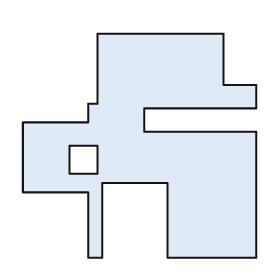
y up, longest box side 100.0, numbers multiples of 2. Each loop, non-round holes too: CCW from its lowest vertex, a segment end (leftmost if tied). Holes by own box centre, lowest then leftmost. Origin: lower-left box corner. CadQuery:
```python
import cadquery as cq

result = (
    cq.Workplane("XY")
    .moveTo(28.0, 0.0)
    .lineTo(34.0, 0.0)
    .lineTo(34.0, 32.0)
    .lineTo(62.0, 32.0)
    .lineTo(62.0, 0.0)
    .lineTo(100.0, 0.0)
    .lineTo(100.0, 54.0)
    .lineTo(52.0, 54.0)
    .lineTo(52.0, 64.0)
    .lineTo(100.0, 64.0)
    .lineTo(100.0, 74.0)
    .lineTo(86.0, 74.0)
    .lineTo(86.0, 96.0)
    .lineTo(32.0, 96.0)
    .lineTo(32.0, 66.0)
    .lineTo(28.0, 66.0)
    .lineTo(28.0, 58.0)
    .lineTo(0.0, 58.0)
    .lineTo(0.0, 28.0)
    .lineTo(28.0, 28.0)
    .close()
    .moveTo(20.0, 36.0)
    .lineTo(32.0, 36.0)
    .lineTo(32.0, 48.0)
    .lineTo(20.0, 48.0)
    .close()
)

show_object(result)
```